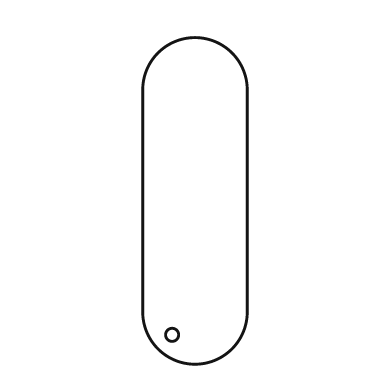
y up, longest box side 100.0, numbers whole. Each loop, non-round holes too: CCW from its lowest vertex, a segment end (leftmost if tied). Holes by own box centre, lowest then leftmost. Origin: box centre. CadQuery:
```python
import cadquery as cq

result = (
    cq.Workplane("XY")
    .moveTo(-16.0, -34.0)
    .threePointArc((0.0, -50.0), (16.0, -34.0))
    .lineTo(16.0, 34.0)
    .threePointArc((0.0, 50.0), (-16.0, 34.0))
    .close()
    .moveTo(-7.0, -41.0)
    .circle(2.0)
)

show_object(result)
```